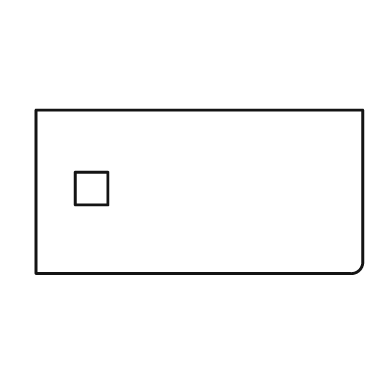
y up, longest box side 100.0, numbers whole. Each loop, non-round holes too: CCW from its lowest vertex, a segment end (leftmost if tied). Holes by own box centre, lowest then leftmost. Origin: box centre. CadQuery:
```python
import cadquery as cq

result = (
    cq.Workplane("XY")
    .moveTo(-50.0, -25.0)
    .lineTo(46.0, -25.0)
    .threePointArc((49.0, -24.0), (50.0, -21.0))
    .lineTo(50.0, 25.0)
    .lineTo(-50.0, 25.0)
    .close()
    .moveTo(-38.0, -4.0)
    .lineTo(-28.0, -4.0)
    .lineTo(-28.0, 6.0)
    .lineTo(-38.0, 6.0)
    .close()
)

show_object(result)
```